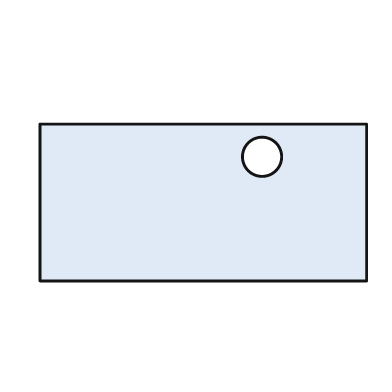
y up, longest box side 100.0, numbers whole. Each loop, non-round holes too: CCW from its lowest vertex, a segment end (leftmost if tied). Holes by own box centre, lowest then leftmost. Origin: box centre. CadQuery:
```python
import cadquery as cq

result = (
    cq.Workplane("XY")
    .moveTo(-50.0, -24.0)
    .lineTo(50.0, -24.0)
    .lineTo(50.0, 24.0)
    .lineTo(-50.0, 24.0)
    .close()
    .moveTo(18.0, 14.0)
    .circle(6.0)
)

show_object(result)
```